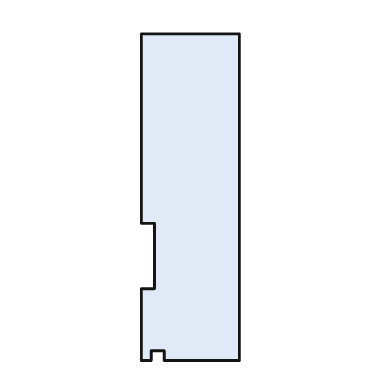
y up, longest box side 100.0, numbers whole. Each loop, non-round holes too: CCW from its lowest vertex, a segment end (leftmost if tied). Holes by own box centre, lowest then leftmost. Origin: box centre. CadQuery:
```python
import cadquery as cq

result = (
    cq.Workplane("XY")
    .moveTo(-15.0, -50.0)
    .lineTo(-12.0, -50.0)
    .lineTo(-12.0, -47.0)
    .lineTo(-8.0, -47.0)
    .lineTo(-8.0, -50.0)
    .lineTo(15.0, -50.0)
    .lineTo(15.0, 50.0)
    .lineTo(-15.0, 50.0)
    .lineTo(-15.0, -8.0)
    .lineTo(-11.0, -8.0)
    .lineTo(-11.0, -28.0)
    .lineTo(-15.0, -28.0)
    .close()
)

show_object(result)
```